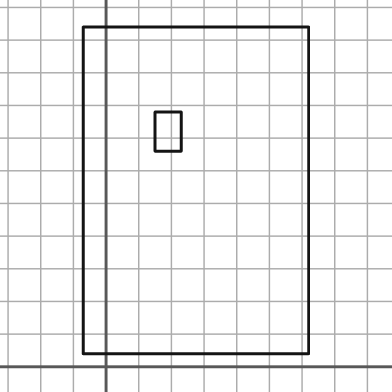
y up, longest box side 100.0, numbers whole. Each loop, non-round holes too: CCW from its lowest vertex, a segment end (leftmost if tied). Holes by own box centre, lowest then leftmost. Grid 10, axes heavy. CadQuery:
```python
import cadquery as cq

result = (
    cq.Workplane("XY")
    .moveTo(-7.0, 4.0)
    .lineTo(62.0, 4.0)
    .lineTo(62.0, 104.0)
    .lineTo(-7.0, 104.0)
    .close()
    .moveTo(15.0, 66.0)
    .lineTo(23.0, 66.0)
    .lineTo(23.0, 78.0)
    .lineTo(15.0, 78.0)
    .close()
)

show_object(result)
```